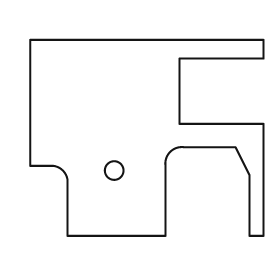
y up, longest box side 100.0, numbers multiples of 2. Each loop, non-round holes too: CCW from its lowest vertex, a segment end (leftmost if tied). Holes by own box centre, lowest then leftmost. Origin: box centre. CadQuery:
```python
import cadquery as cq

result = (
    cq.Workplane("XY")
    .moveTo(-34.0, -42.0)
    .lineTo(8.0, -42.0)
    .lineTo(8.0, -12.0)
    .threePointArc((10.0, -6.0), (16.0, -4.0))
    .lineTo(38.0, -4.0)
    .lineTo(44.0, -16.0)
    .lineTo(44.0, -42.0)
    .lineTo(50.0, -42.0)
    .lineTo(50.0, 6.0)
    .lineTo(14.0, 6.0)
    .lineTo(14.0, 34.0)
    .lineTo(50.0, 34.0)
    .lineTo(50.0, 42.0)
    .lineTo(-50.0, 42.0)
    .lineTo(-50.0, -12.0)
    .lineTo(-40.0, -12.0)
    .threePointArc((-36.0, -14.0), (-34.0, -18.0))
    .close()
    .moveTo(-14.0, -14.0)
    .circle(4.0)
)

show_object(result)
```